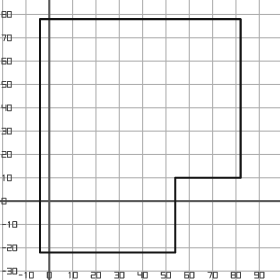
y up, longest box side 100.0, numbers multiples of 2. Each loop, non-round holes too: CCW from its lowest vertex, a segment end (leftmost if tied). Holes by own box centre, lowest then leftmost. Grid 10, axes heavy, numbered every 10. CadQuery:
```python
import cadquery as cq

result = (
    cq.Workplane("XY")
    .moveTo(-4.0, -22.0)
    .lineTo(54.0, -22.0)
    .lineTo(54.0, 10.0)
    .lineTo(82.0, 10.0)
    .lineTo(82.0, 78.0)
    .lineTo(-4.0, 78.0)
    .close()
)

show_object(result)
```